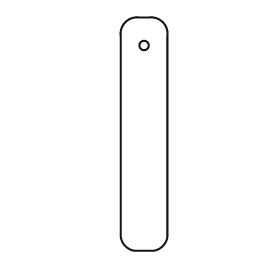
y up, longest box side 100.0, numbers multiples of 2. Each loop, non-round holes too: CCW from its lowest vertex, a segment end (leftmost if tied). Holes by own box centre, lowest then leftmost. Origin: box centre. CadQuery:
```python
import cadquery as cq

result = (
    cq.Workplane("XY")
    .moveTo(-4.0, -50.0)
    .lineTo(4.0, -50.0)
    .threePointArc((8.0, -48.0), (10.0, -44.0))
    .lineTo(10.0, 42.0)
    .threePointArc((8.0, 48.0), (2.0, 50.0))
    .lineTo(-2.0, 50.0)
    .threePointArc((-8.0, 48.0), (-10.0, 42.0))
    .lineTo(-10.0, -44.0)
    .threePointArc((-8.0, -48.0), (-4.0, -50.0))
    .close()
    .moveTo(0.0, 38.0)
    .circle(2.0)
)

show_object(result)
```